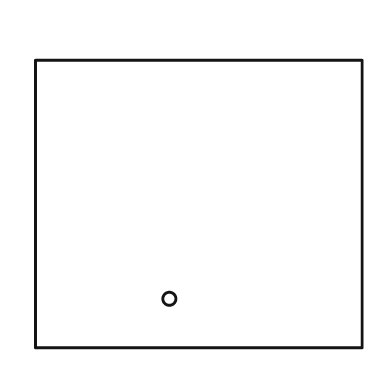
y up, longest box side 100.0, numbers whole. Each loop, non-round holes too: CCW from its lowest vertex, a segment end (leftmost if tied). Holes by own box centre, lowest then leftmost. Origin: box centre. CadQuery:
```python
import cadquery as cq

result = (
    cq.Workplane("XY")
    .moveTo(-50.0, -44.0)
    .lineTo(50.0, -44.0)
    .lineTo(50.0, 44.0)
    .lineTo(-50.0, 44.0)
    .close()
    .moveTo(-9.0, -29.0)
    .circle(2.0)
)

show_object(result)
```